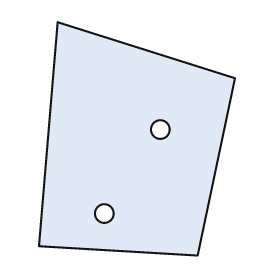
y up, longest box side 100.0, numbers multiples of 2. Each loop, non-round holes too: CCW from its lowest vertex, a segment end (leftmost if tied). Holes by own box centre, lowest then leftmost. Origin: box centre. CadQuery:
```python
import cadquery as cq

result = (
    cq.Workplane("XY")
    .moveTo(26.0, -50.0)
    .lineTo(42.0, 26.0)
    .lineTo(-34.0, 50.0)
    .lineTo(-42.0, -46.0)
    .close()
    .moveTo(-14.0, -32.0)
    .circle(4.0)
    .moveTo(10.0, 4.0)
    .circle(4.0)
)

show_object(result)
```